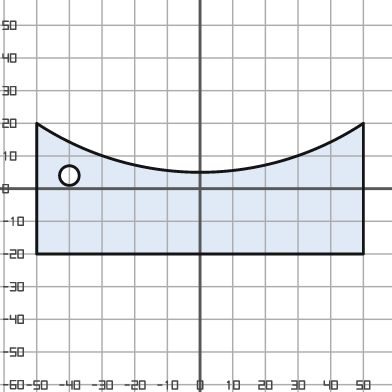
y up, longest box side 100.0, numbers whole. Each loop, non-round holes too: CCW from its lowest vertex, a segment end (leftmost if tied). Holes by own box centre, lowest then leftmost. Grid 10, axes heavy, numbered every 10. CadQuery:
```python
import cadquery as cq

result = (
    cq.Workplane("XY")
    .moveTo(-50.0, -20.0)
    .lineTo(50.0, -20.0)
    .lineTo(50.0, 20.0)
    .threePointArc((0.0, 5.0), (-50.0, 20.0))
    .close()
    .moveTo(-40.0, 4.0)
    .circle(3.0)
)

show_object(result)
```